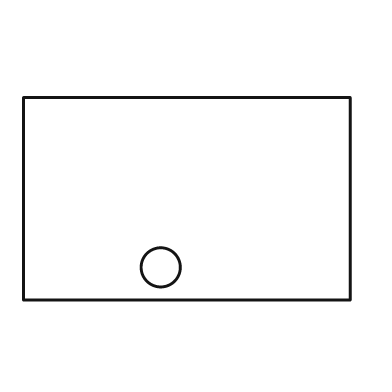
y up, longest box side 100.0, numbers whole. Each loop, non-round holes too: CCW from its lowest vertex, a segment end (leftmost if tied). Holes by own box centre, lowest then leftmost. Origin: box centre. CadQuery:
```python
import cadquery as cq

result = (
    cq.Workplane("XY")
    .moveTo(-50.0, -31.0)
    .lineTo(50.0, -31.0)
    .lineTo(50.0, 31.0)
    .lineTo(-50.0, 31.0)
    .close()
    .moveTo(-8.0, -21.0)
    .circle(6.0)
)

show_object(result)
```